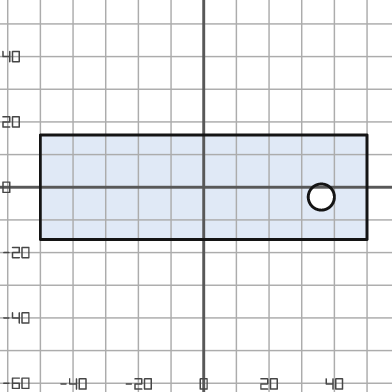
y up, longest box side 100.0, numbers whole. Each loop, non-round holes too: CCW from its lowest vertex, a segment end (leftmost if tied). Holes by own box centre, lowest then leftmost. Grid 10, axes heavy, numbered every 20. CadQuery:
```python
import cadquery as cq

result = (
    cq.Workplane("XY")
    .moveTo(-50.0, -16.0)
    .lineTo(50.0, -16.0)
    .lineTo(50.0, 16.0)
    .lineTo(-50.0, 16.0)
    .close()
    .moveTo(36.0, -3.0)
    .circle(4.0)
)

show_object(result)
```